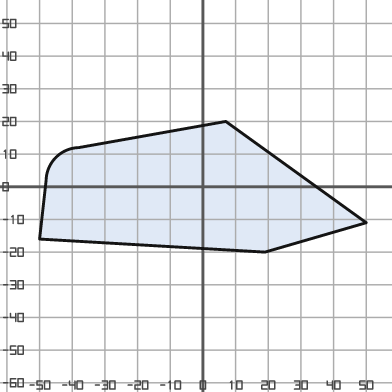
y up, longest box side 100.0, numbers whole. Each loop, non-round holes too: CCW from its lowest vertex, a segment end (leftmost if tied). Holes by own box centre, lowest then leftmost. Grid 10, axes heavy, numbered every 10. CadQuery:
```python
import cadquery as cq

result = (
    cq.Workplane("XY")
    .moveTo(19.0, -20.0)
    .lineTo(50.0, -11.0)
    .lineTo(7.0, 20.0)
    .lineTo(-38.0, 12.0)
    .threePointArc((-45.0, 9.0), (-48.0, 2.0))
    .lineTo(-50.0, -16.0)
    .close()
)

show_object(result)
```